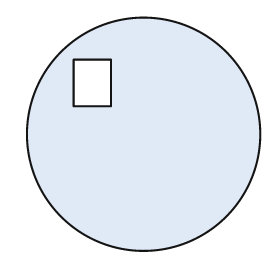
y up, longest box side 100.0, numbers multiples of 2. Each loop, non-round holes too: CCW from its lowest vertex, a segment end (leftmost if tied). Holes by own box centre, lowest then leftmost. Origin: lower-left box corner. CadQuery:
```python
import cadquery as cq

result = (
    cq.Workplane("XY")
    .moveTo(50.0, 50.0)
    .circle(50.0)
    .moveTo(20.0, 62.0)
    .lineTo(36.0, 62.0)
    .lineTo(36.0, 82.0)
    .lineTo(20.0, 82.0)
    .close()
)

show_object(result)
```